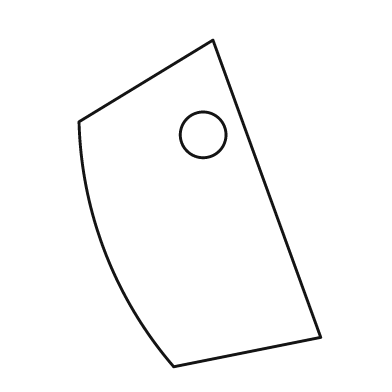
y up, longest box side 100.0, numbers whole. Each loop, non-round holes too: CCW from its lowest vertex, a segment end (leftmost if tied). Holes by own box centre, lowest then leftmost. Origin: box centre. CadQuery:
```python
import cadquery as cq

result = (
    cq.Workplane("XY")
    .moveTo(-8.0, -50.0)
    .lineTo(37.0, -41.0)
    .lineTo(4.0, 50.0)
    .lineTo(-37.0, 25.0)
    .threePointArc((-29.0, -15.0), (-8.0, -50.0))
    .close()
    .moveTo(1.0, 21.0)
    .circle(7.0)
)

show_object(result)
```